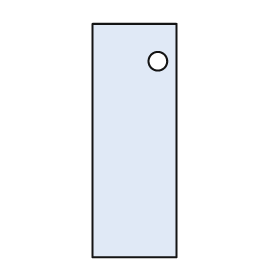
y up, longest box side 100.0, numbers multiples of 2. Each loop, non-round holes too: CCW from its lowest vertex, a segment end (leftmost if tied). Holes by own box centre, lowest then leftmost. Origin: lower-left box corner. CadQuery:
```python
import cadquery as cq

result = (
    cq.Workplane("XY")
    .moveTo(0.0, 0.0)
    .lineTo(36.0, 0.0)
    .lineTo(36.0, 100.0)
    .lineTo(0.0, 100.0)
    .close()
    .moveTo(28.0, 84.0)
    .circle(4.0)
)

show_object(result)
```